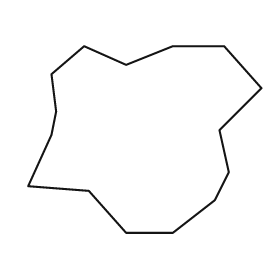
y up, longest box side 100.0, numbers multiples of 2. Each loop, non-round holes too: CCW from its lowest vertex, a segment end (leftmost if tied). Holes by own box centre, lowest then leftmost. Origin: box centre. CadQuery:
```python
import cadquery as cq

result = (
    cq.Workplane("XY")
    .moveTo(-8.0, -40.0)
    .lineTo(12.0, -40.0)
    .lineTo(30.0, -26.0)
    .lineTo(36.0, -14.0)
    .lineTo(32.0, 4.0)
    .lineTo(50.0, 22.0)
    .lineTo(34.0, 40.0)
    .lineTo(12.0, 40.0)
    .lineTo(-8.0, 32.0)
    .lineTo(-26.0, 40.0)
    .lineTo(-40.0, 28.0)
    .lineTo(-38.0, 12.0)
    .lineTo(-40.0, 2.0)
    .lineTo(-50.0, -20.0)
    .lineTo(-24.0, -22.0)
    .close()
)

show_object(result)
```